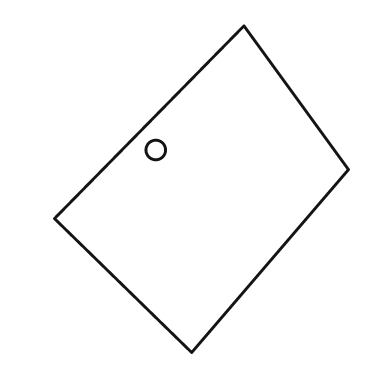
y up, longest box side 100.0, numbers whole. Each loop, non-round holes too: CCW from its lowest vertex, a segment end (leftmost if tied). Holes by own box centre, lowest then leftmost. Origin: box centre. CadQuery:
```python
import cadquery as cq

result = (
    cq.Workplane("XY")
    .moveTo(-3.0, -50.0)
    .lineTo(45.0, 6.0)
    .lineTo(13.0, 50.0)
    .lineTo(-45.0, -9.0)
    .close()
    .moveTo(-14.0, 12.0)
    .circle(3.0)
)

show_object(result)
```